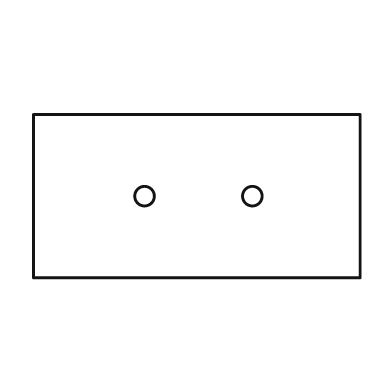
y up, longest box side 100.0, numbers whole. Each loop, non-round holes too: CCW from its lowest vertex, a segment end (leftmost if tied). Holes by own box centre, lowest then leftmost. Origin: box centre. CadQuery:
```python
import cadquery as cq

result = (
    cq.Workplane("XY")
    .moveTo(-50.0, -25.0)
    .lineTo(50.0, -25.0)
    .lineTo(50.0, 25.0)
    .lineTo(-50.0, 25.0)
    .close()
    .moveTo(-16.0, 0.0)
    .circle(3.0)
    .moveTo(17.0, 0.0)
    .circle(3.0)
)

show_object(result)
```